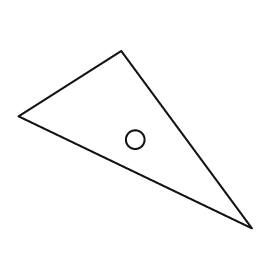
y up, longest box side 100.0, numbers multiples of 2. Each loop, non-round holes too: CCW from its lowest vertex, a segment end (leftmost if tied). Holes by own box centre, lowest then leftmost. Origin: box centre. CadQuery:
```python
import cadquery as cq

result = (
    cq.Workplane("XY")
    .moveTo(50.0, -38.0)
    .lineTo(-6.0, 38.0)
    .lineTo(-50.0, 10.0)
    .close()
    .moveTo(0.0, 0.0)
    .circle(4.0)
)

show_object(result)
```